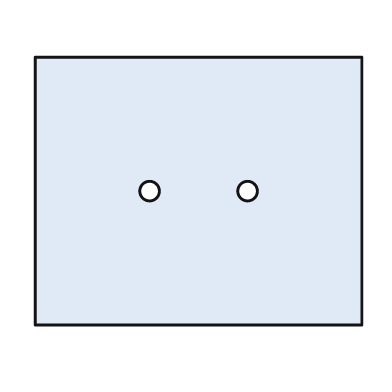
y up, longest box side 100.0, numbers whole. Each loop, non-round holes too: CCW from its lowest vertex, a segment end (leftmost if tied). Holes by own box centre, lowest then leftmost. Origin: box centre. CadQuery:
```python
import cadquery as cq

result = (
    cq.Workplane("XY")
    .moveTo(-50.0, -41.0)
    .lineTo(50.0, -41.0)
    .lineTo(50.0, 41.0)
    .lineTo(-50.0, 41.0)
    .close()
    .moveTo(-15.0, 0.0)
    .circle(3.0)
    .moveTo(15.0, 0.0)
    .circle(3.0)
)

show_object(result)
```